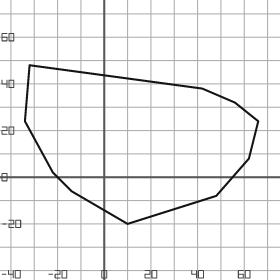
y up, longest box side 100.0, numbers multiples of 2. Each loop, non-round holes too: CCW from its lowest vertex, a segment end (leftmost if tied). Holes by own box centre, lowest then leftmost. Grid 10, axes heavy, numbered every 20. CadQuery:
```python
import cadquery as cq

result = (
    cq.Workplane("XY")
    .moveTo(10.0, -20.0)
    .lineTo(48.0, -8.0)
    .lineTo(62.0, 8.0)
    .lineTo(66.0, 24.0)
    .lineTo(56.0, 32.0)
    .lineTo(42.0, 38.0)
    .lineTo(-32.0, 48.0)
    .lineTo(-34.0, 24.0)
    .lineTo(-22.0, 2.0)
    .lineTo(-14.0, -6.0)
    .close()
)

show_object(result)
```